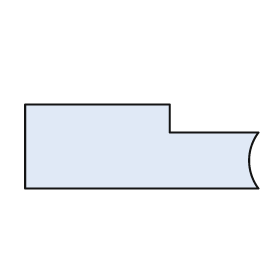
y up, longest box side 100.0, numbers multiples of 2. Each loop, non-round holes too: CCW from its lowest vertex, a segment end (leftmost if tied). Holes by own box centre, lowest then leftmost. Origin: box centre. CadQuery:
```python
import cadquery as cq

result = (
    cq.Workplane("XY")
    .moveTo(-50.0, -18.0)
    .lineTo(50.0, -18.0)
    .threePointArc((46.0, -6.0), (50.0, 6.0))
    .lineTo(12.0, 6.0)
    .lineTo(12.0, 18.0)
    .lineTo(-50.0, 18.0)
    .close()
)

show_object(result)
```